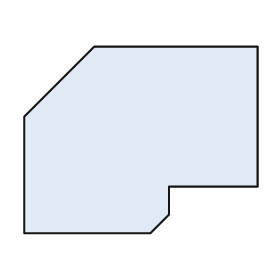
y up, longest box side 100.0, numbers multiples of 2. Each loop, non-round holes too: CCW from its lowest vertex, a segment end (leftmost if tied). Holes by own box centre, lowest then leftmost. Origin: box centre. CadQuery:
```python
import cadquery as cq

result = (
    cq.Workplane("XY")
    .moveTo(-50.0, -40.0)
    .lineTo(4.0, -40.0)
    .lineTo(12.0, -32.0)
    .lineTo(12.0, -20.0)
    .lineTo(50.0, -20.0)
    .lineTo(50.0, 40.0)
    .lineTo(-20.0, 40.0)
    .lineTo(-50.0, 10.0)
    .close()
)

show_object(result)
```